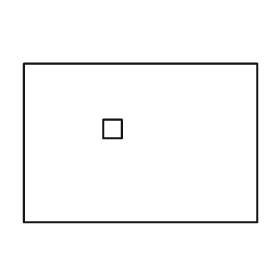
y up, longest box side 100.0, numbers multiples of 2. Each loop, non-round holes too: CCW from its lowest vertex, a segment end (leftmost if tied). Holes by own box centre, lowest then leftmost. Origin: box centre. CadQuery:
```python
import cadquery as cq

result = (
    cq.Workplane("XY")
    .moveTo(-50.0, -34.0)
    .lineTo(50.0, -34.0)
    .lineTo(50.0, 34.0)
    .lineTo(-50.0, 34.0)
    .close()
    .moveTo(-16.0, 2.0)
    .lineTo(-8.0, 2.0)
    .lineTo(-8.0, 10.0)
    .lineTo(-16.0, 10.0)
    .close()
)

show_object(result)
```